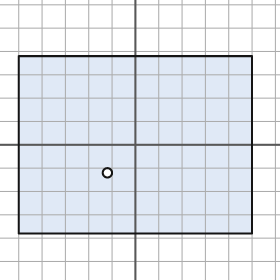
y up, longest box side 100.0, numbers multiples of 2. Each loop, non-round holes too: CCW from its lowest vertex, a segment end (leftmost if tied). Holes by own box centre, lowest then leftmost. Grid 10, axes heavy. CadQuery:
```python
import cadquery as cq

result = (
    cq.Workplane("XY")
    .moveTo(-50.0, -38.0)
    .lineTo(50.0, -38.0)
    .lineTo(50.0, 38.0)
    .lineTo(-50.0, 38.0)
    .close()
    .moveTo(-12.0, -12.0)
    .circle(2.0)
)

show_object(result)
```